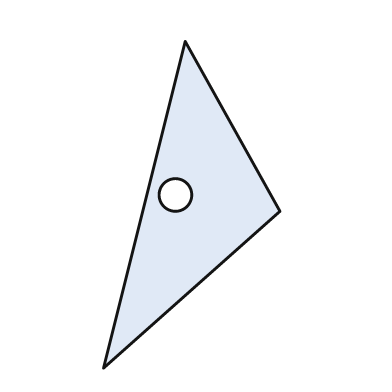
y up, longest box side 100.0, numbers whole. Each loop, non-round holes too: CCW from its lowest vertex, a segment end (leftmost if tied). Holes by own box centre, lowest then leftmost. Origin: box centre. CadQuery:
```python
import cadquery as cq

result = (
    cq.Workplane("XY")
    .moveTo(-27.0, -50.0)
    .lineTo(27.0, -2.0)
    .lineTo(-2.0, 50.0)
    .close()
    .moveTo(-5.0, 3.0)
    .circle(5.0)
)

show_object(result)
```